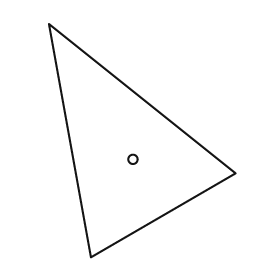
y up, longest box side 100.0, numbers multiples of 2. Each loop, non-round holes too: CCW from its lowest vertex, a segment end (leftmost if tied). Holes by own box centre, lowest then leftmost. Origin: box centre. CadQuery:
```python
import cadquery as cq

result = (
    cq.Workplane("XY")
    .moveTo(-22.0, -50.0)
    .lineTo(40.0, -14.0)
    .lineTo(-40.0, 50.0)
    .close()
    .moveTo(-4.0, -8.0)
    .circle(2.0)
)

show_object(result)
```